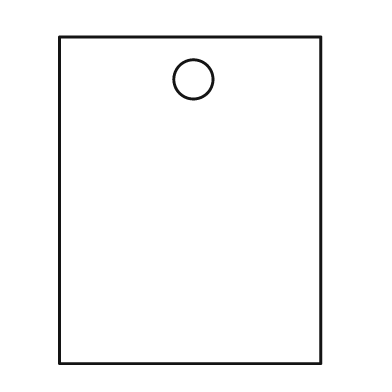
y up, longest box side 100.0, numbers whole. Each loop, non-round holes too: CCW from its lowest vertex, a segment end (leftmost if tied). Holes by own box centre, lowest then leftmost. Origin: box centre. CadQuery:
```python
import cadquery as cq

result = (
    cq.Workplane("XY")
    .moveTo(-40.0, -50.0)
    .lineTo(40.0, -50.0)
    .lineTo(40.0, 50.0)
    .lineTo(-40.0, 50.0)
    .close()
    .moveTo(1.0, 37.0)
    .circle(6.0)
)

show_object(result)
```